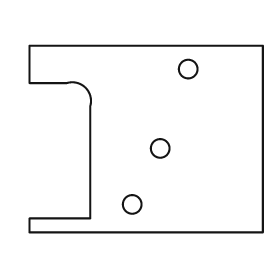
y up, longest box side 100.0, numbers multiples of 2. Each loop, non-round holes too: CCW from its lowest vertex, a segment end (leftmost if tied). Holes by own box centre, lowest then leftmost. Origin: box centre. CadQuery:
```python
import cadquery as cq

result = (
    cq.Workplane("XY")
    .moveTo(-50.0, -40.0)
    .lineTo(50.0, -40.0)
    .lineTo(50.0, 40.0)
    .lineTo(-50.0, 40.0)
    .lineTo(-50.0, 24.0)
    .lineTo(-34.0, 24.0)
    .threePointArc((-26.0, 22.0), (-24.0, 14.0))
    .lineTo(-24.0, -34.0)
    .lineTo(-50.0, -34.0)
    .close()
    .moveTo(-6.0, -28.0)
    .circle(4.0)
    .moveTo(6.0, -4.0)
    .circle(4.0)
    .moveTo(18.0, 30.0)
    .circle(4.0)
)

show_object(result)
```